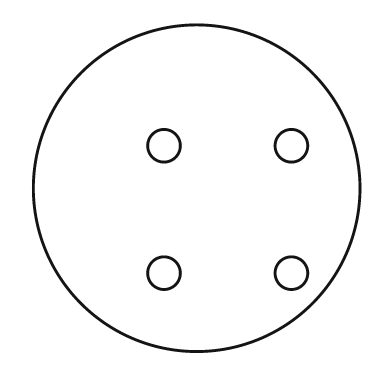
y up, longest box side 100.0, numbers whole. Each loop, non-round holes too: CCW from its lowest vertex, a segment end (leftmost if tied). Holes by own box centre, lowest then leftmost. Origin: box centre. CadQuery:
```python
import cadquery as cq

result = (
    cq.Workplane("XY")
    .moveTo(0.0, 0.0)
    .circle(50.0)
    .moveTo(-10.0, -26.0)
    .circle(5.0)
    .moveTo(29.0, -26.0)
    .circle(5.0)
    .moveTo(-10.0, 13.0)
    .circle(5.0)
    .moveTo(29.0, 13.0)
    .circle(5.0)
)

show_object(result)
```